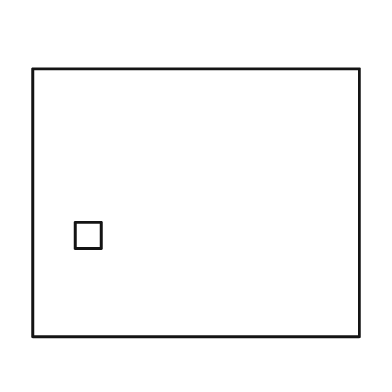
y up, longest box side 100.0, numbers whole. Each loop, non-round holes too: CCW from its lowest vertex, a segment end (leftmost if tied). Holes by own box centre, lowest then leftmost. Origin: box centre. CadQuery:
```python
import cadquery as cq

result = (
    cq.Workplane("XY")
    .moveTo(-50.0, -41.0)
    .lineTo(50.0, -41.0)
    .lineTo(50.0, 41.0)
    .lineTo(-50.0, 41.0)
    .close()
    .moveTo(-37.0, -14.0)
    .lineTo(-29.0, -14.0)
    .lineTo(-29.0, -6.0)
    .lineTo(-37.0, -6.0)
    .close()
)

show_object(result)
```